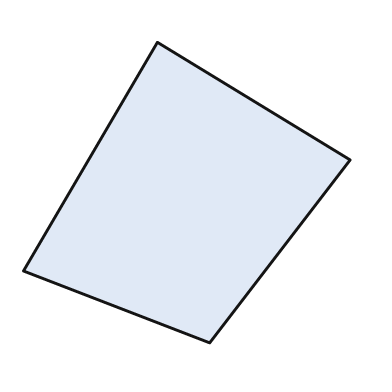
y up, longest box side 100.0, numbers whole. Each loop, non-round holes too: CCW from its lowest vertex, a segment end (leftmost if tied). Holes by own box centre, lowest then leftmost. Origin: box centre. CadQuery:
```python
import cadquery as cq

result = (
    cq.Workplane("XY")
    .moveTo(7.0, -46.0)
    .lineTo(50.0, 10.0)
    .lineTo(-9.0, 46.0)
    .lineTo(-50.0, -24.0)
    .close()
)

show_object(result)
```